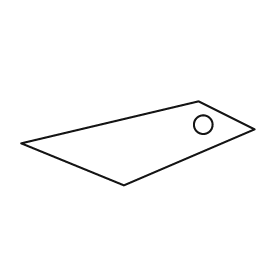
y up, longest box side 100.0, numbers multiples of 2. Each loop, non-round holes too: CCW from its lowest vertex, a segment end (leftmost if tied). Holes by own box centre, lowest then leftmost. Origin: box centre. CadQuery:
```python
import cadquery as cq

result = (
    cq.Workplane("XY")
    .moveTo(-6.0, -18.0)
    .lineTo(50.0, 6.0)
    .lineTo(26.0, 18.0)
    .lineTo(-50.0, 0.0)
    .close()
    .moveTo(28.0, 8.0)
    .circle(4.0)
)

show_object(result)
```